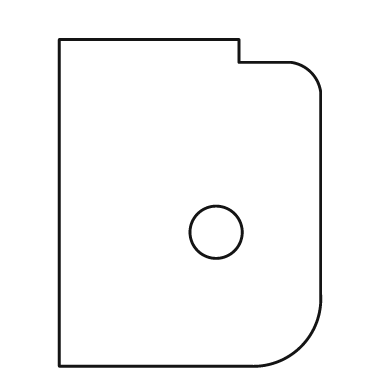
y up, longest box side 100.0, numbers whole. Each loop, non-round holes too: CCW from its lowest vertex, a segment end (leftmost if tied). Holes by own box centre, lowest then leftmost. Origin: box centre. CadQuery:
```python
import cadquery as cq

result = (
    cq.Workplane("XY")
    .moveTo(-40.0, -50.0)
    .lineTo(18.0, -50.0)
    .threePointArc((34.0, -44.0), (40.0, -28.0))
    .lineTo(40.0, 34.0)
    .threePointArc((37.0, 40.0), (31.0, 43.0))
    .lineTo(15.0, 43.0)
    .lineTo(15.0, 50.0)
    .lineTo(-40.0, 50.0)
    .close()
    .moveTo(8.0, -9.0)
    .circle(8.0)
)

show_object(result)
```